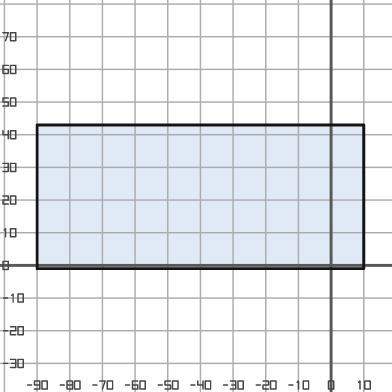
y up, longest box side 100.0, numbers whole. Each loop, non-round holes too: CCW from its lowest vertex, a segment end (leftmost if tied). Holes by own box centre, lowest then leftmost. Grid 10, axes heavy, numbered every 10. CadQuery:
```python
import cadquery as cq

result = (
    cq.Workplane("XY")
    .moveTo(-90.0, -1.0)
    .lineTo(10.0, -1.0)
    .lineTo(10.0, 43.0)
    .lineTo(-90.0, 43.0)
    .close()
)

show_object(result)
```